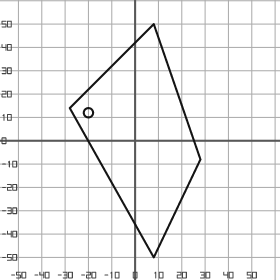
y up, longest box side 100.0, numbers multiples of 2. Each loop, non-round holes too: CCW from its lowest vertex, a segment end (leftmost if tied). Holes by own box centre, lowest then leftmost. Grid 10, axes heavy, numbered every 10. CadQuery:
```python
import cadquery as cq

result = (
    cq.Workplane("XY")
    .moveTo(8.0, -50.0)
    .lineTo(28.0, -8.0)
    .lineTo(8.0, 50.0)
    .lineTo(-28.0, 14.0)
    .close()
    .moveTo(-20.0, 12.0)
    .circle(2.0)
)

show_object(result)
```